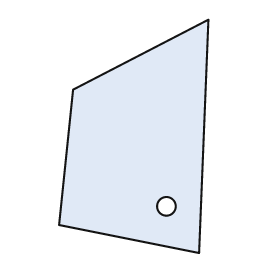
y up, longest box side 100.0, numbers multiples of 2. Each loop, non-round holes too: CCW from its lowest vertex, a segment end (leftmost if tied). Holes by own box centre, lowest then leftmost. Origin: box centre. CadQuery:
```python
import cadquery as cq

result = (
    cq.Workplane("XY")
    .moveTo(28.0, -50.0)
    .lineTo(32.0, 50.0)
    .lineTo(-26.0, 20.0)
    .lineTo(-32.0, -38.0)
    .close()
    .moveTo(14.0, -30.0)
    .circle(4.0)
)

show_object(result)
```